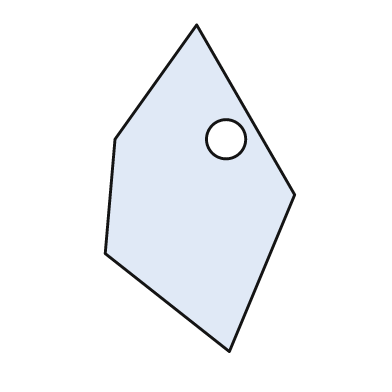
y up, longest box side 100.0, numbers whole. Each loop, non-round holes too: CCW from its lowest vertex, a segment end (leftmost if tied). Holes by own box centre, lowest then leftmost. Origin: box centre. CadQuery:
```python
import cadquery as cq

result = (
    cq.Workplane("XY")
    .moveTo(9.0, -50.0)
    .lineTo(29.0, -2.0)
    .lineTo(-1.0, 50.0)
    .lineTo(-26.0, 15.0)
    .lineTo(-29.0, -20.0)
    .close()
    .moveTo(8.0, 15.0)
    .circle(6.0)
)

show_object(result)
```